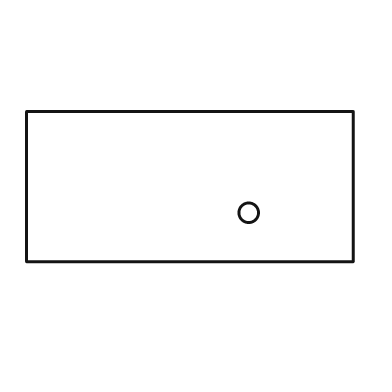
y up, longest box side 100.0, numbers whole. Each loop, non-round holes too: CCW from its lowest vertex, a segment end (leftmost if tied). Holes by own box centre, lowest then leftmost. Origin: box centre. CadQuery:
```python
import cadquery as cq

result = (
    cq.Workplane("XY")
    .moveTo(-50.0, -23.0)
    .lineTo(50.0, -23.0)
    .lineTo(50.0, 23.0)
    .lineTo(-50.0, 23.0)
    .close()
    .moveTo(18.0, -8.0)
    .circle(3.0)
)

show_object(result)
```